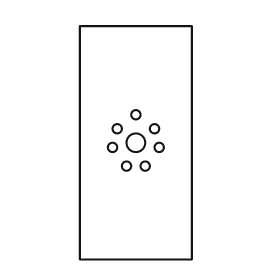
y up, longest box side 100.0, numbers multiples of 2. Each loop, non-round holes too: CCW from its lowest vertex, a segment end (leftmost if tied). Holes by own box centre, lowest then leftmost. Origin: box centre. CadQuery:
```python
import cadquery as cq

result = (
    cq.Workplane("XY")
    .moveTo(-24.0, -50.0)
    .lineTo(24.0, -50.0)
    .lineTo(24.0, 50.0)
    .lineTo(-24.0, 50.0)
    .close()
    .moveTo(-4.0, -10.0)
    .circle(2.0)
    .moveTo(4.0, -10.0)
    .circle(2.0)
    .moveTo(-10.0, -2.0)
    .circle(2.0)
    .moveTo(10.0, -2.0)
    .circle(2.0)
    .moveTo(0.0, 0.0)
    .circle(4.0)
    .moveTo(-8.0, 6.0)
    .circle(2.0)
    .moveTo(8.0, 6.0)
    .circle(2.0)
    .moveTo(0.0, 12.0)
    .circle(2.0)
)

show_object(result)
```